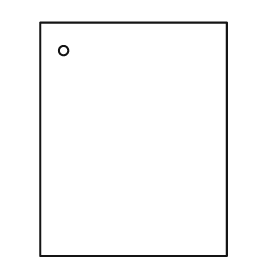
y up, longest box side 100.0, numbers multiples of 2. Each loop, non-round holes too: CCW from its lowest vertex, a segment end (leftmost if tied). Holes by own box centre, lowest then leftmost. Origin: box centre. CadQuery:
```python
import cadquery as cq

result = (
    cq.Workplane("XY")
    .moveTo(-40.0, -50.0)
    .lineTo(40.0, -50.0)
    .lineTo(40.0, 50.0)
    .lineTo(-40.0, 50.0)
    .close()
    .moveTo(-30.0, 38.0)
    .circle(2.0)
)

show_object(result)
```